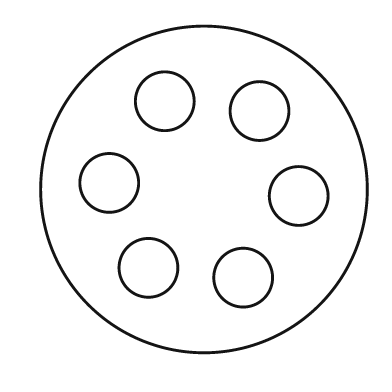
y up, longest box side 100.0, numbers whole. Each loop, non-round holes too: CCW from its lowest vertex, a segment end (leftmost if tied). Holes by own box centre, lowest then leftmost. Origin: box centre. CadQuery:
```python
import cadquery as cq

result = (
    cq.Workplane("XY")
    .moveTo(0.0, 0.0)
    .circle(50.0)
    .moveTo(12.0, -27.0)
    .circle(9.0)
    .moveTo(-17.0, -24.0)
    .circle(9.0)
    .moveTo(29.0, -2.0)
    .circle(9.0)
    .moveTo(-29.0, 2.0)
    .circle(9.0)
    .moveTo(17.0, 24.0)
    .circle(9.0)
    .moveTo(-12.0, 27.0)
    .circle(9.0)
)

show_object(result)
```